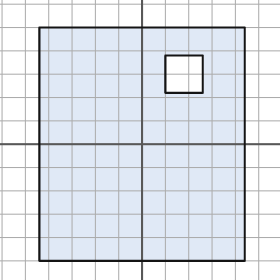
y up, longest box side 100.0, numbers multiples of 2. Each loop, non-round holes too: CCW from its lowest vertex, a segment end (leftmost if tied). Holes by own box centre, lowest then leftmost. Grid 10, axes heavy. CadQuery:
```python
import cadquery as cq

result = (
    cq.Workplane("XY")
    .moveTo(-44.0, -50.0)
    .lineTo(44.0, -50.0)
    .lineTo(44.0, 50.0)
    .lineTo(-44.0, 50.0)
    .close()
    .moveTo(10.0, 22.0)
    .lineTo(26.0, 22.0)
    .lineTo(26.0, 38.0)
    .lineTo(10.0, 38.0)
    .close()
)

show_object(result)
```